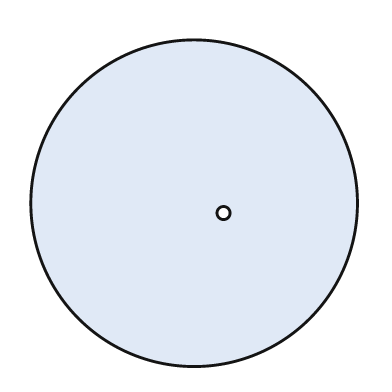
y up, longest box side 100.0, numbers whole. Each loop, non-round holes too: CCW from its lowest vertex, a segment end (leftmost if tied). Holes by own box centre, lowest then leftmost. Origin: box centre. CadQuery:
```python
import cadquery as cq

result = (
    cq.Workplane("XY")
    .moveTo(0.0, 0.0)
    .circle(50.0)
    .moveTo(9.0, -3.0)
    .circle(2.0)
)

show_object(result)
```